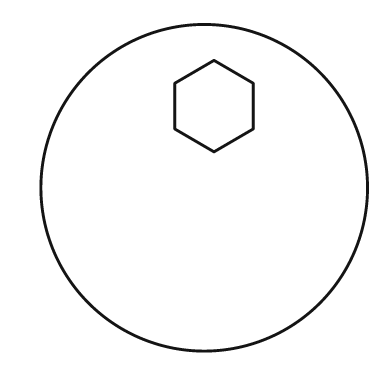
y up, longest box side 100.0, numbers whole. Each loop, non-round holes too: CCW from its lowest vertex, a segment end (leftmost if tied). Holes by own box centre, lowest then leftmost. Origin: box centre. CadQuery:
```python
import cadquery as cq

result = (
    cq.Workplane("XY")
    .moveTo(0.0, 0.0)
    .circle(50.0)
    .moveTo(3.0, 11.0)
    .lineTo(15.0, 18.0)
    .lineTo(15.0, 32.0)
    .lineTo(3.0, 39.0)
    .lineTo(-9.0, 32.0)
    .lineTo(-9.0, 18.0)
    .close()
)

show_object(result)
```